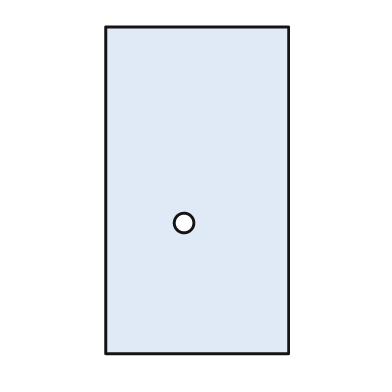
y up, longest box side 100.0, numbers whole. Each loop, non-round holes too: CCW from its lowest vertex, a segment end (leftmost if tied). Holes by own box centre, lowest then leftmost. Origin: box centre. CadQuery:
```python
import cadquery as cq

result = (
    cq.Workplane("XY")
    .moveTo(-28.0, -50.0)
    .lineTo(28.0, -50.0)
    .lineTo(28.0, 50.0)
    .lineTo(-28.0, 50.0)
    .close()
    .moveTo(-4.0, -10.0)
    .circle(3.0)
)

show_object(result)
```